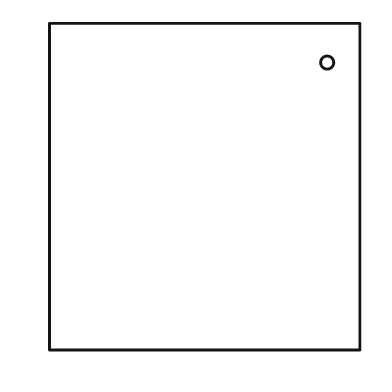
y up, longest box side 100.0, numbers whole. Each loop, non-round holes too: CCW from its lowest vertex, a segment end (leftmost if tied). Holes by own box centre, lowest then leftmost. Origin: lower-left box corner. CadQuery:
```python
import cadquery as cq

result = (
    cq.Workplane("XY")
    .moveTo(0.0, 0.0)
    .lineTo(95.0, 0.0)
    .lineTo(95.0, 100.0)
    .lineTo(0.0, 100.0)
    .close()
    .moveTo(85.0, 88.0)
    .circle(2.0)
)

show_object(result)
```